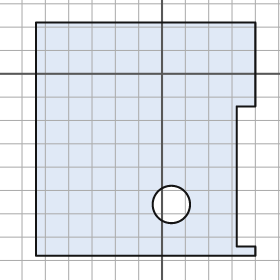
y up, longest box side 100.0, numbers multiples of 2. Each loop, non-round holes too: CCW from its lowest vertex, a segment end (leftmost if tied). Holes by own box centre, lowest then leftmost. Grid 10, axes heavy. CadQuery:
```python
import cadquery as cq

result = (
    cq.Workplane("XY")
    .moveTo(-54.0, -78.0)
    .lineTo(40.0, -78.0)
    .lineTo(40.0, -74.0)
    .lineTo(32.0, -74.0)
    .lineTo(32.0, -14.0)
    .lineTo(40.0, -14.0)
    .lineTo(40.0, 22.0)
    .lineTo(-54.0, 22.0)
    .close()
    .moveTo(4.0, -56.0)
    .circle(8.0)
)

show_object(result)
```